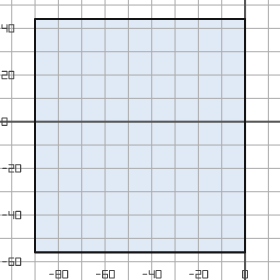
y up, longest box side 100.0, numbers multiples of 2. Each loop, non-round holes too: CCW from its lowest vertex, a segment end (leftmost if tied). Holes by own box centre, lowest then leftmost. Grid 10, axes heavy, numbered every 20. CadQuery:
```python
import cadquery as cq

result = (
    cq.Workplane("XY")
    .moveTo(-90.0, -56.0)
    .lineTo(0.0, -56.0)
    .lineTo(0.0, 44.0)
    .lineTo(-90.0, 44.0)
    .close()
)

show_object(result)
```